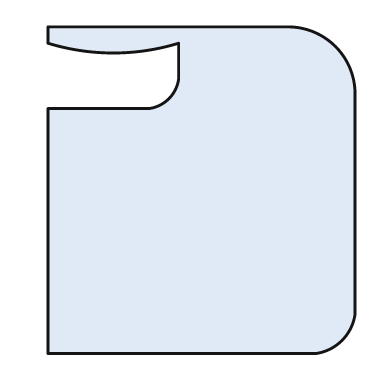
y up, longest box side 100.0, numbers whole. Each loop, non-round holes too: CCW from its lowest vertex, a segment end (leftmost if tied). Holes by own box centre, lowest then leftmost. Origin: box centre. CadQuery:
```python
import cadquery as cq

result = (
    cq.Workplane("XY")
    .moveTo(-47.0, -50.0)
    .lineTo(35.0, -50.0)
    .threePointArc((43.0, -46.0), (47.0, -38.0))
    .lineTo(47.0, 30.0)
    .threePointArc((41.0, 44.0), (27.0, 50.0))
    .lineTo(-47.0, 50.0)
    .lineTo(-47.0, 45.0)
    .threePointArc((-27.0, 42.0), (-7.0, 45.0))
    .lineTo(-7.0, 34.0)
    .threePointArc((-10.0, 28.0), (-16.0, 25.0))
    .lineTo(-47.0, 25.0)
    .close()
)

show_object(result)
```